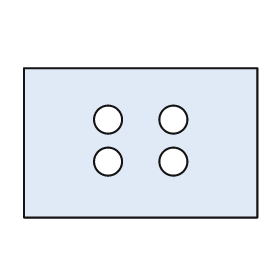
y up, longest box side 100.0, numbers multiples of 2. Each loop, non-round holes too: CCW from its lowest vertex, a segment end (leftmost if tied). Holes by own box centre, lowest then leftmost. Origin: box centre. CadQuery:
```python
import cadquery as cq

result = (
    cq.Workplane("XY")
    .moveTo(-50.0, -32.0)
    .lineTo(50.0, -32.0)
    .lineTo(50.0, 32.0)
    .lineTo(-50.0, 32.0)
    .close()
    .moveTo(-14.0, -8.0)
    .circle(6.0)
    .moveTo(14.0, -8.0)
    .circle(6.0)
    .moveTo(-14.0, 10.0)
    .circle(6.0)
    .moveTo(14.0, 10.0)
    .circle(6.0)
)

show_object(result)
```